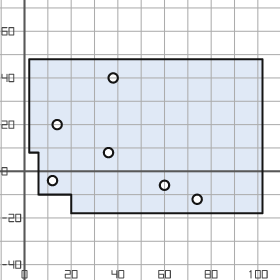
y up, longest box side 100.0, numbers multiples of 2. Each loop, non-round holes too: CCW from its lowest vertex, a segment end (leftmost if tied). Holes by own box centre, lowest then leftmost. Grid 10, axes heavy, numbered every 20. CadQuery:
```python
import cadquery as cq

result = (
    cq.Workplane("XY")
    .moveTo(20.0, -18.0)
    .lineTo(102.0, -18.0)
    .lineTo(102.0, 48.0)
    .lineTo(2.0, 48.0)
    .lineTo(2.0, 8.0)
    .lineTo(6.0, 8.0)
    .lineTo(6.0, -10.0)
    .lineTo(20.0, -10.0)
    .close()
    .moveTo(74.0, -12.0)
    .circle(2.0)
    .moveTo(60.0, -6.0)
    .circle(2.0)
    .moveTo(12.0, -4.0)
    .circle(2.0)
    .moveTo(36.0, 8.0)
    .circle(2.0)
    .moveTo(14.0, 20.0)
    .circle(2.0)
    .moveTo(38.0, 40.0)
    .circle(2.0)
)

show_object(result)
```